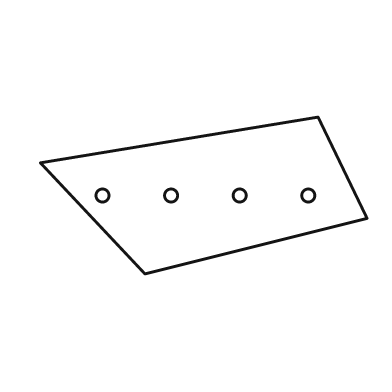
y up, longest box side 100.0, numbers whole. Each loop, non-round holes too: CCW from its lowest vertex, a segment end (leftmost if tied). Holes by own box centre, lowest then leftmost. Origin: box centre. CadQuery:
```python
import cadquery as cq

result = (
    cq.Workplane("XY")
    .moveTo(-18.0, -24.0)
    .lineTo(50.0, -7.0)
    .lineTo(35.0, 24.0)
    .lineTo(-50.0, 10.0)
    .close()
    .moveTo(-31.0, 0.0)
    .circle(2.0)
    .moveTo(-10.0, 0.0)
    .circle(2.0)
    .moveTo(11.0, 0.0)
    .circle(2.0)
    .moveTo(32.0, 0.0)
    .circle(2.0)
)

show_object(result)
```